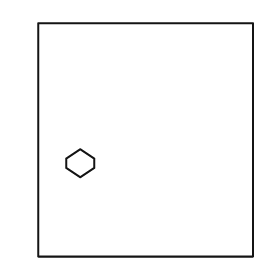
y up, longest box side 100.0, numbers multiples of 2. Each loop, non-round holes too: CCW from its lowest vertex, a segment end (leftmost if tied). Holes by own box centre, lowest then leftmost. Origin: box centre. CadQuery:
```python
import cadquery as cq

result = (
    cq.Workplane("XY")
    .moveTo(-46.0, -50.0)
    .lineTo(46.0, -50.0)
    .lineTo(46.0, 50.0)
    .lineTo(-46.0, 50.0)
    .close()
    .moveTo(-28.0, -16.0)
    .lineTo(-22.0, -12.0)
    .lineTo(-22.0, -8.0)
    .lineTo(-28.0, -4.0)
    .lineTo(-34.0, -8.0)
    .lineTo(-34.0, -12.0)
    .close()
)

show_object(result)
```